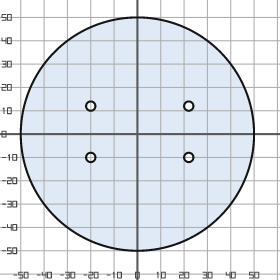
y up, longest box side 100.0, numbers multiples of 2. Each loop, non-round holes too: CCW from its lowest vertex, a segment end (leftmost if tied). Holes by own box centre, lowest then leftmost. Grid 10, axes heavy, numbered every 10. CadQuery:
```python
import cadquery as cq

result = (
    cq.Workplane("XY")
    .moveTo(0.0, 0.0)
    .circle(50.0)
    .moveTo(-20.0, -10.0)
    .circle(2.0)
    .moveTo(22.0, -10.0)
    .circle(2.0)
    .moveTo(-20.0, 12.0)
    .circle(2.0)
    .moveTo(22.0, 12.0)
    .circle(2.0)
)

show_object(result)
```